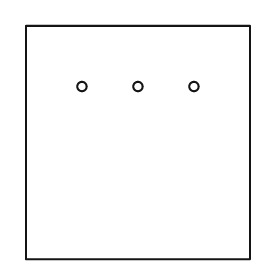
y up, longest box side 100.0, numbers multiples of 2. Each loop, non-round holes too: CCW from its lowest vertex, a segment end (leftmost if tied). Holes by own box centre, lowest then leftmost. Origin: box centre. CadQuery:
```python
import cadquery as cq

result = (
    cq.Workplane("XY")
    .moveTo(-48.0, -50.0)
    .lineTo(48.0, -50.0)
    .lineTo(48.0, 50.0)
    .lineTo(-48.0, 50.0)
    .close()
    .moveTo(-24.0, 24.0)
    .circle(2.0)
    .moveTo(0.0, 24.0)
    .circle(2.0)
    .moveTo(24.0, 24.0)
    .circle(2.0)
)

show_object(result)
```